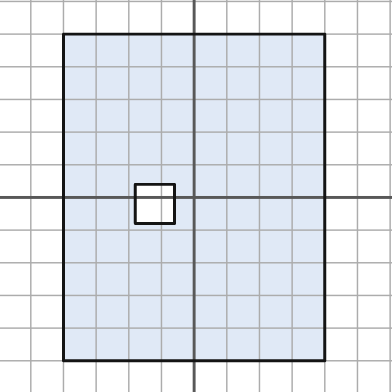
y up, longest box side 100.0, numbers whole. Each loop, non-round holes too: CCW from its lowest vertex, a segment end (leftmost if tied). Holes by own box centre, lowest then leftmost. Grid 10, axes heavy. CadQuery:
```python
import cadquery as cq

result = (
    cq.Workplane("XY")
    .moveTo(-40.0, -50.0)
    .lineTo(40.0, -50.0)
    .lineTo(40.0, 50.0)
    .lineTo(-40.0, 50.0)
    .close()
    .moveTo(-18.0, -8.0)
    .lineTo(-6.0, -8.0)
    .lineTo(-6.0, 4.0)
    .lineTo(-18.0, 4.0)
    .close()
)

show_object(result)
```